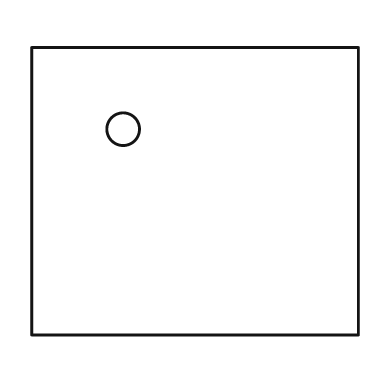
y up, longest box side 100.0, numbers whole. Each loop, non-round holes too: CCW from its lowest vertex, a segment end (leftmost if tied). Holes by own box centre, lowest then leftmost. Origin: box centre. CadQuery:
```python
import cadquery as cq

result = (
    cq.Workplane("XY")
    .moveTo(-50.0, -44.0)
    .lineTo(50.0, -44.0)
    .lineTo(50.0, 44.0)
    .lineTo(-50.0, 44.0)
    .close()
    .moveTo(-22.0, 19.0)
    .circle(5.0)
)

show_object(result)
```